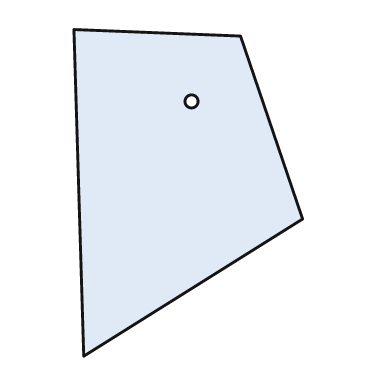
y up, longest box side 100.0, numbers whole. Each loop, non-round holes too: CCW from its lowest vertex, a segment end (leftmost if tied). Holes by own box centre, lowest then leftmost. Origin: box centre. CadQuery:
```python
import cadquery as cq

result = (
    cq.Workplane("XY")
    .moveTo(-32.0, -50.0)
    .lineTo(35.0, -8.0)
    .lineTo(16.0, 48.0)
    .lineTo(-35.0, 50.0)
    .close()
    .moveTo(1.0, 28.0)
    .circle(2.0)
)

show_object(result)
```